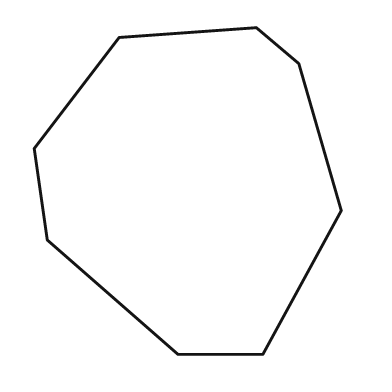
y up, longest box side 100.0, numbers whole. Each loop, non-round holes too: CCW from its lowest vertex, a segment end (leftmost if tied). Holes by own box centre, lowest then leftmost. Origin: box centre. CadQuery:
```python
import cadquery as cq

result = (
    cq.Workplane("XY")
    .moveTo(-3.0, -50.0)
    .lineTo(23.0, -50.0)
    .lineTo(47.0, -6.0)
    .lineTo(34.0, 39.0)
    .lineTo(21.0, 50.0)
    .lineTo(-21.0, 47.0)
    .lineTo(-47.0, 13.0)
    .lineTo(-43.0, -15.0)
    .close()
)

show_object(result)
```